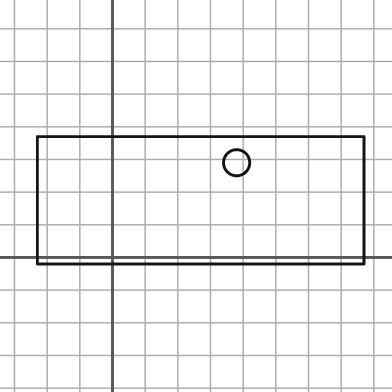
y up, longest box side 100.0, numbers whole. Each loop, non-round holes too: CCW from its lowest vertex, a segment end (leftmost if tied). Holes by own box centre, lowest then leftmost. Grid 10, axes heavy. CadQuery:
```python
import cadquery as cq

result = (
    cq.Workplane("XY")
    .moveTo(-23.0, -2.0)
    .lineTo(77.0, -2.0)
    .lineTo(77.0, 37.0)
    .lineTo(-23.0, 37.0)
    .close()
    .moveTo(38.0, 29.0)
    .circle(4.0)
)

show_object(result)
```